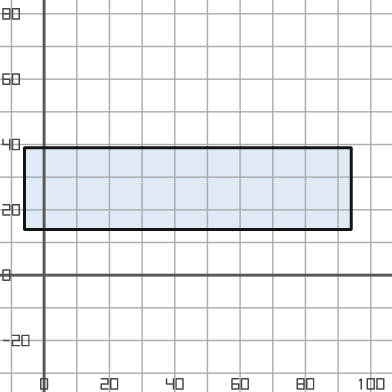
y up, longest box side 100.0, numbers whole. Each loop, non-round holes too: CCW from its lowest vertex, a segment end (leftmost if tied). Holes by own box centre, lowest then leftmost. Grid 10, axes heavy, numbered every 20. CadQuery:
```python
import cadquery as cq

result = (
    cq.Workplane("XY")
    .moveTo(-6.0, 14.0)
    .lineTo(94.0, 14.0)
    .lineTo(94.0, 39.0)
    .lineTo(-6.0, 39.0)
    .close()
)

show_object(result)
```